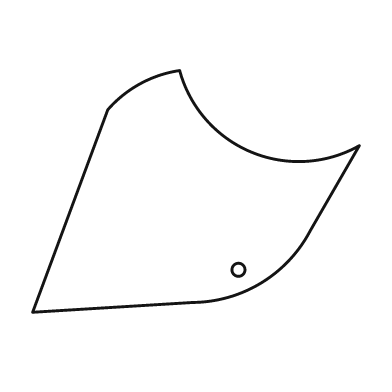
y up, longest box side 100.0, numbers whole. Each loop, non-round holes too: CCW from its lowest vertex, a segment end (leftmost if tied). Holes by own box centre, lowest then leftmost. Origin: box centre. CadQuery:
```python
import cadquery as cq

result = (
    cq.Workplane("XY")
    .moveTo(-50.0, -37.0)
    .lineTo(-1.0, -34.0)
    .threePointArc((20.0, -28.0), (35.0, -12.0))
    .lineTo(50.0, 14.0)
    .threePointArc((17.0, 12.0), (-5.0, 37.0))
    .threePointArc((-17.0, 33.0), (-27.0, 25.0))
    .close()
    .moveTo(13.0, -24.0)
    .circle(2.0)
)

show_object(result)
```